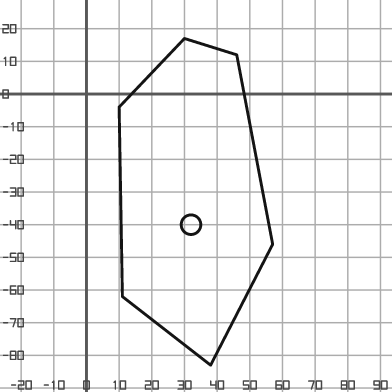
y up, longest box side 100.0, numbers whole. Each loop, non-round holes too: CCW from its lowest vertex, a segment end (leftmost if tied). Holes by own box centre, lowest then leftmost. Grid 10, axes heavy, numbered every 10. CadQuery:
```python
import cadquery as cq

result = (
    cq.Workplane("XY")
    .moveTo(38.0, -83.0)
    .lineTo(57.0, -46.0)
    .lineTo(46.0, 12.0)
    .lineTo(30.0, 17.0)
    .lineTo(10.0, -4.0)
    .lineTo(11.0, -62.0)
    .close()
    .moveTo(32.0, -40.0)
    .circle(3.0)
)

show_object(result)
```